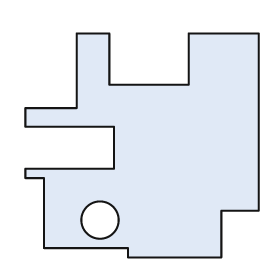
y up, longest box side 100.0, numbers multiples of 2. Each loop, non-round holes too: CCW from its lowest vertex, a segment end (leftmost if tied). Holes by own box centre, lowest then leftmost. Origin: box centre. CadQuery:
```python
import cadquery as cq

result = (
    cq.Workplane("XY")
    .moveTo(-6.0, -48.0)
    .lineTo(34.0, -48.0)
    .lineTo(34.0, -28.0)
    .lineTo(50.0, -28.0)
    .lineTo(50.0, 48.0)
    .lineTo(20.0, 48.0)
    .lineTo(20.0, 26.0)
    .lineTo(-14.0, 26.0)
    .lineTo(-14.0, 48.0)
    .lineTo(-28.0, 48.0)
    .lineTo(-28.0, 16.0)
    .lineTo(-50.0, 16.0)
    .lineTo(-50.0, 8.0)
    .lineTo(-12.0, 8.0)
    .lineTo(-12.0, -10.0)
    .lineTo(-50.0, -10.0)
    .lineTo(-50.0, -14.0)
    .lineTo(-42.0, -14.0)
    .lineTo(-42.0, -44.0)
    .lineTo(-6.0, -44.0)
    .close()
    .moveTo(-18.0, -32.0)
    .circle(8.0)
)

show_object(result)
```